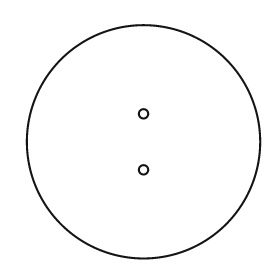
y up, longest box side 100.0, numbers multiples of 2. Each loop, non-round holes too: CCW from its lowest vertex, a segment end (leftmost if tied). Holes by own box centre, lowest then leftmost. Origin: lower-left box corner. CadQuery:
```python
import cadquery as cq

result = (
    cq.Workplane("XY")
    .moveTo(50.0, 50.0)
    .circle(50.0)
    .moveTo(50.0, 38.0)
    .circle(2.0)
    .moveTo(50.0, 62.0)
    .circle(2.0)
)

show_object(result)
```